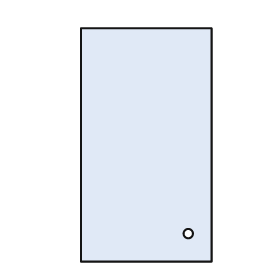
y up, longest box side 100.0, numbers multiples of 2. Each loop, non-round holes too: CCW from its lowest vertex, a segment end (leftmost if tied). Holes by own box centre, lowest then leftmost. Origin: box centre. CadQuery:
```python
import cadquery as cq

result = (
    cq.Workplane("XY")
    .moveTo(-28.0, -50.0)
    .lineTo(28.0, -50.0)
    .lineTo(28.0, 50.0)
    .lineTo(-28.0, 50.0)
    .close()
    .moveTo(18.0, -38.0)
    .circle(2.0)
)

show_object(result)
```